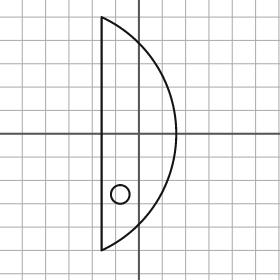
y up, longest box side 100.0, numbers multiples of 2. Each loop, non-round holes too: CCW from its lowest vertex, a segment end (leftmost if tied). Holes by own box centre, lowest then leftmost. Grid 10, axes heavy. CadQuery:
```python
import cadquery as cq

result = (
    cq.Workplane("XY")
    .moveTo(-16.0, -50.0)
    .threePointArc((16.0, 0.0), (-16.0, 50.0))
    .close()
    .moveTo(-8.0, -26.0)
    .circle(4.0)
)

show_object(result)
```